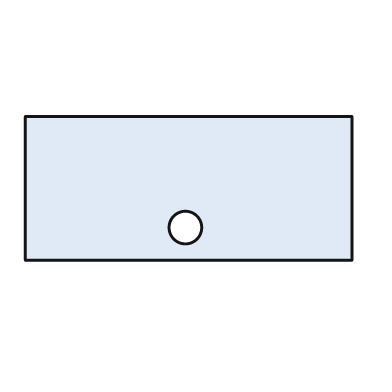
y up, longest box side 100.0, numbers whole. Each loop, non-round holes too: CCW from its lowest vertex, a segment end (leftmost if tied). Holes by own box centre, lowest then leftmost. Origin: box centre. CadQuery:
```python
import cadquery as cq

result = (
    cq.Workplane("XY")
    .moveTo(-50.0, -22.0)
    .lineTo(50.0, -22.0)
    .lineTo(50.0, 22.0)
    .lineTo(-50.0, 22.0)
    .close()
    .moveTo(-1.0, -12.0)
    .circle(5.0)
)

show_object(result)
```